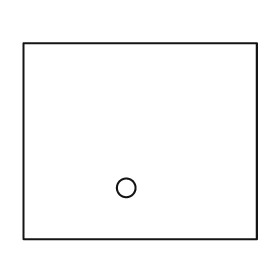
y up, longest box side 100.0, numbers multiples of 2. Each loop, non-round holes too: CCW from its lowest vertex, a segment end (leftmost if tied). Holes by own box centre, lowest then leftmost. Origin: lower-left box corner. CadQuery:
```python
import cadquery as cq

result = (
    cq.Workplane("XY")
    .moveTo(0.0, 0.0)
    .lineTo(100.0, 0.0)
    .lineTo(100.0, 84.0)
    .lineTo(0.0, 84.0)
    .close()
    .moveTo(44.0, 22.0)
    .circle(4.0)
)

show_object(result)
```